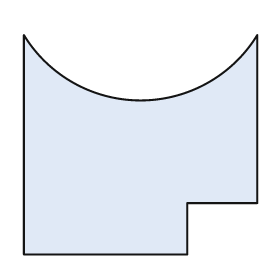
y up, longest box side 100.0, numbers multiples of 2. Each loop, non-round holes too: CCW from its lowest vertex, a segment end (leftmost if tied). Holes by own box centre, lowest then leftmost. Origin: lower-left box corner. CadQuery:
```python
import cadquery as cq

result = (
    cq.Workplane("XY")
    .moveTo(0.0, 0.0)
    .lineTo(70.0, 0.0)
    .lineTo(70.0, 22.0)
    .lineTo(100.0, 22.0)
    .lineTo(100.0, 94.0)
    .threePointArc((50.0, 66.0), (0.0, 94.0))
    .close()
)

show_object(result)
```